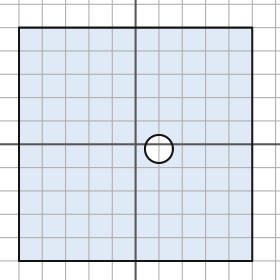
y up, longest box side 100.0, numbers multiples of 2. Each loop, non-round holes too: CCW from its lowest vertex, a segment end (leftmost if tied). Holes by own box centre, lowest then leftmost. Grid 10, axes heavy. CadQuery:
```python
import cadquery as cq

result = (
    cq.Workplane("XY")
    .moveTo(-50.0, -50.0)
    .lineTo(50.0, -50.0)
    .lineTo(50.0, 50.0)
    .lineTo(-50.0, 50.0)
    .close()
    .moveTo(10.0, -2.0)
    .circle(6.0)
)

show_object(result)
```